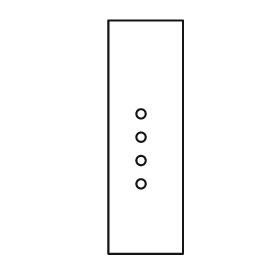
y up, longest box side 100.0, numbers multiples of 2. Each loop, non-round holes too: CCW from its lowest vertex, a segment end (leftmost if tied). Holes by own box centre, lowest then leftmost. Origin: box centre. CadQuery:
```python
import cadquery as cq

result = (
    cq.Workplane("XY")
    .moveTo(-16.0, -50.0)
    .lineTo(16.0, -50.0)
    .lineTo(16.0, 50.0)
    .lineTo(-16.0, 50.0)
    .close()
    .moveTo(-2.0, -20.0)
    .circle(2.0)
    .moveTo(-2.0, -10.0)
    .circle(2.0)
    .moveTo(-2.0, 0.0)
    .circle(2.0)
    .moveTo(-2.0, 10.0)
    .circle(2.0)
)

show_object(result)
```